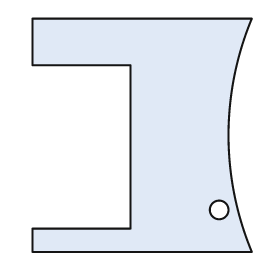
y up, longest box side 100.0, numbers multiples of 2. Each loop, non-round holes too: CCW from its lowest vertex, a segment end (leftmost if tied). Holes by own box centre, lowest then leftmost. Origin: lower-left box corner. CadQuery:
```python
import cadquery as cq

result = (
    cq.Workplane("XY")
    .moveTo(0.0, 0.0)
    .lineTo(94.0, 0.0)
    .threePointArc((84.0, 50.0), (94.0, 100.0))
    .lineTo(0.0, 100.0)
    .lineTo(0.0, 80.0)
    .lineTo(42.0, 80.0)
    .lineTo(42.0, 10.0)
    .lineTo(0.0, 10.0)
    .close()
    .moveTo(80.0, 18.0)
    .circle(4.0)
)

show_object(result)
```